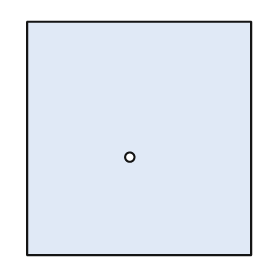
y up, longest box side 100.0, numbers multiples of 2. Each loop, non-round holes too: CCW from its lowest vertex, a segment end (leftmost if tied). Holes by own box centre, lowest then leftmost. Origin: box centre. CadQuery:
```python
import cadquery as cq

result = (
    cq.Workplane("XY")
    .moveTo(-48.0, -50.0)
    .lineTo(48.0, -50.0)
    .lineTo(48.0, 50.0)
    .lineTo(-48.0, 50.0)
    .close()
    .moveTo(-4.0, -8.0)
    .circle(2.0)
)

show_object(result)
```